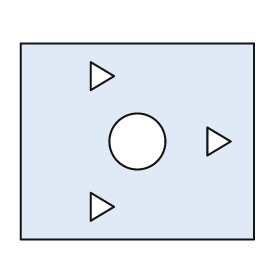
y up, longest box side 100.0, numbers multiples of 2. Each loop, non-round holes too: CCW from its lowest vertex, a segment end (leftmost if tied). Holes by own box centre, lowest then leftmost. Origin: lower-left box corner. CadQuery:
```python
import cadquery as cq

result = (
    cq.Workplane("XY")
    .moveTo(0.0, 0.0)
    .lineTo(100.0, 0.0)
    .lineTo(100.0, 84.0)
    .lineTo(0.0, 84.0)
    .close()
    .moveTo(30.0, 8.0)
    .lineTo(40.0, 14.0)
    .lineTo(30.0, 20.0)
    .close()
    .moveTo(50.0, 42.0)
    .circle(12.0)
    .moveTo(80.0, 36.0)
    .lineTo(90.0, 42.0)
    .lineTo(80.0, 48.0)
    .close()
    .moveTo(30.0, 64.0)
    .lineTo(40.0, 70.0)
    .lineTo(30.0, 76.0)
    .close()
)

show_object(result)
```